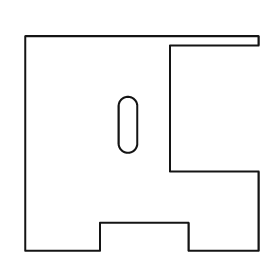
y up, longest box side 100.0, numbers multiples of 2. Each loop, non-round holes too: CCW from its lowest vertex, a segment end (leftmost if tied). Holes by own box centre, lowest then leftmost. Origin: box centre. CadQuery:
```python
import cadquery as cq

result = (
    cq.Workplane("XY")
    .moveTo(-50.0, -46.0)
    .lineTo(-18.0, -46.0)
    .lineTo(-18.0, -34.0)
    .lineTo(20.0, -34.0)
    .lineTo(20.0, -46.0)
    .lineTo(50.0, -46.0)
    .lineTo(50.0, -12.0)
    .lineTo(12.0, -12.0)
    .lineTo(12.0, 42.0)
    .lineTo(50.0, 42.0)
    .lineTo(50.0, 46.0)
    .lineTo(-50.0, 46.0)
    .close()
    .moveTo(-10.0, 0.0)
    .threePointArc((-6.0, -4.0), (-2.0, 0.0))
    .lineTo(-2.0, 16.0)
    .threePointArc((-6.0, 20.0), (-10.0, 16.0))
    .close()
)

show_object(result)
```